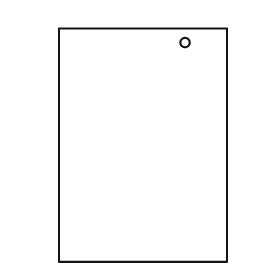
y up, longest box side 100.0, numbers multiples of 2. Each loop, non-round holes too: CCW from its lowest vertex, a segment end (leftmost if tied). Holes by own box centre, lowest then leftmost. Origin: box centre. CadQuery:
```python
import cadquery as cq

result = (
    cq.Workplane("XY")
    .moveTo(-36.0, -50.0)
    .lineTo(36.0, -50.0)
    .lineTo(36.0, 50.0)
    .lineTo(-36.0, 50.0)
    .close()
    .moveTo(18.0, 44.0)
    .circle(2.0)
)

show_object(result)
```